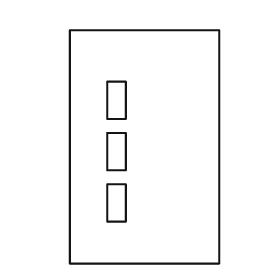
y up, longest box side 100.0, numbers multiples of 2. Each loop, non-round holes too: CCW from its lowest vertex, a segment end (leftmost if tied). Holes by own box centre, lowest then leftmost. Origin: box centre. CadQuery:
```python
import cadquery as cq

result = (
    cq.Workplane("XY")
    .moveTo(-32.0, -50.0)
    .lineTo(32.0, -50.0)
    .lineTo(32.0, 50.0)
    .lineTo(-32.0, 50.0)
    .close()
    .moveTo(-16.0, -32.0)
    .lineTo(-8.0, -32.0)
    .lineTo(-8.0, -16.0)
    .lineTo(-16.0, -16.0)
    .close()
    .moveTo(-16.0, -10.0)
    .lineTo(-8.0, -10.0)
    .lineTo(-8.0, 6.0)
    .lineTo(-16.0, 6.0)
    .close()
    .moveTo(-16.0, 12.0)
    .lineTo(-8.0, 12.0)
    .lineTo(-8.0, 28.0)
    .lineTo(-16.0, 28.0)
    .close()
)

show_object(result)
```